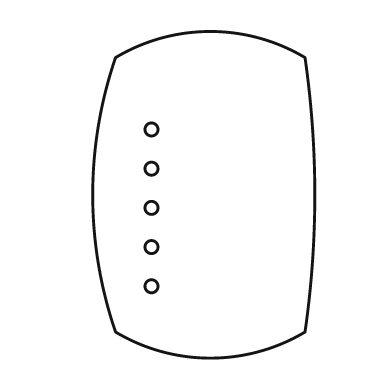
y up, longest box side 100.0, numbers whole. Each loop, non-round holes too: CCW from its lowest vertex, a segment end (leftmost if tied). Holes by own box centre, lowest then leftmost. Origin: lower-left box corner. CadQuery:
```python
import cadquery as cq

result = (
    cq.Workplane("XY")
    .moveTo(7.0, 8.0)
    .threePointArc((36.0, 0.0), (65.0, 8.0))
    .threePointArc((68.0, 50.0), (65.0, 92.0))
    .threePointArc((36.0, 100.0), (7.0, 92.0))
    .threePointArc((0.0, 50.0), (7.0, 8.0))
    .close()
    .moveTo(18.0, 22.0)
    .circle(2.0)
    .moveTo(18.0, 34.0)
    .circle(2.0)
    .moveTo(18.0, 46.0)
    .circle(2.0)
    .moveTo(18.0, 58.0)
    .circle(2.0)
    .moveTo(18.0, 70.0)
    .circle(2.0)
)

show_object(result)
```